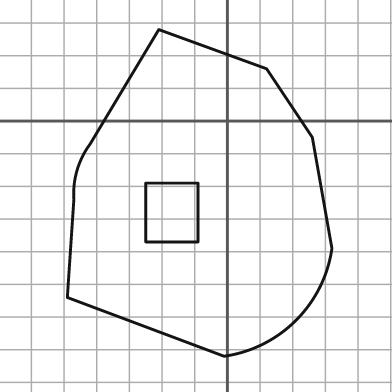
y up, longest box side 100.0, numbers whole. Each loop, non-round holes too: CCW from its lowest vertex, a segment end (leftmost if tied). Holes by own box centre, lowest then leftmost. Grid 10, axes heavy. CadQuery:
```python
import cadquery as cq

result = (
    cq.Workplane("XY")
    .moveTo(-1.0, -72.0)
    .threePointArc((21.0, -61.0), (32.0, -39.0))
    .lineTo(26.0, -5.0)
    .lineTo(12.0, 16.0)
    .lineTo(-21.0, 28.0)
    .lineTo(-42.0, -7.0)
    .threePointArc((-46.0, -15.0), (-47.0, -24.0))
    .lineTo(-49.0, -54.0)
    .close()
    .moveTo(-25.0, -37.0)
    .lineTo(-9.0, -37.0)
    .lineTo(-9.0, -19.0)
    .lineTo(-25.0, -19.0)
    .close()
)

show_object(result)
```